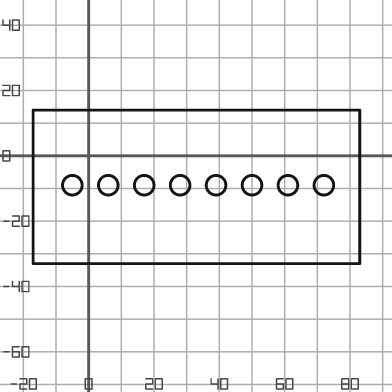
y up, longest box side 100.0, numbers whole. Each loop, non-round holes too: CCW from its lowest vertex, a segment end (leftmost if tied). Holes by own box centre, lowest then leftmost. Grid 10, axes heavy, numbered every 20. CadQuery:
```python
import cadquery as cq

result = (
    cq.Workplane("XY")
    .moveTo(-17.0, -33.0)
    .lineTo(83.0, -33.0)
    .lineTo(83.0, 14.0)
    .lineTo(-17.0, 14.0)
    .close()
    .moveTo(-5.0, -9.0)
    .circle(3.0)
    .moveTo(6.0, -9.0)
    .circle(3.0)
    .moveTo(17.0, -9.0)
    .circle(3.0)
    .moveTo(28.0, -9.0)
    .circle(3.0)
    .moveTo(39.0, -9.0)
    .circle(3.0)
    .moveTo(50.0, -9.0)
    .circle(3.0)
    .moveTo(61.0, -9.0)
    .circle(3.0)
    .moveTo(72.0, -9.0)
    .circle(3.0)
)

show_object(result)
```